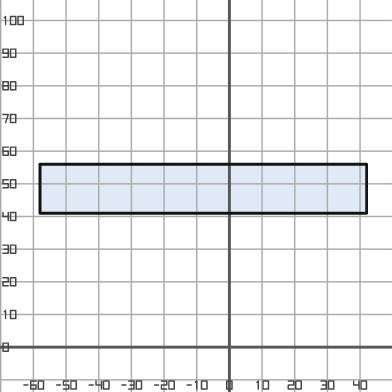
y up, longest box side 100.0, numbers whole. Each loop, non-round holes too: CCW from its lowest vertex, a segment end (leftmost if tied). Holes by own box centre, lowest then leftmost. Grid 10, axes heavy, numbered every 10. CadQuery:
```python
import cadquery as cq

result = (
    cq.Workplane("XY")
    .moveTo(-58.0, 41.0)
    .lineTo(42.0, 41.0)
    .lineTo(42.0, 56.0)
    .lineTo(-58.0, 56.0)
    .close()
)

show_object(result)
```